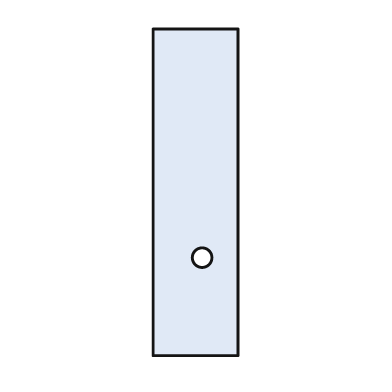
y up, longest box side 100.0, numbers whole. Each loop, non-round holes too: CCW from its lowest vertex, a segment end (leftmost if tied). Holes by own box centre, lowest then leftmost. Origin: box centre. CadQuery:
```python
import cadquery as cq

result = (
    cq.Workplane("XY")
    .moveTo(-13.0, -50.0)
    .lineTo(13.0, -50.0)
    .lineTo(13.0, 50.0)
    .lineTo(-13.0, 50.0)
    .close()
    .moveTo(2.0, -20.0)
    .circle(3.0)
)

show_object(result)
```